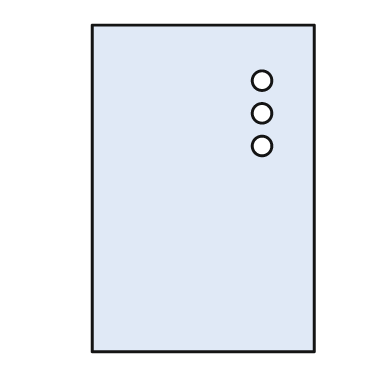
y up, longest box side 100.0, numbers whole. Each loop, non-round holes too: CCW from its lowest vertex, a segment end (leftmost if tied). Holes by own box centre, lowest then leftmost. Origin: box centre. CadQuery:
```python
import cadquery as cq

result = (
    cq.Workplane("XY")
    .moveTo(-34.0, -50.0)
    .lineTo(34.0, -50.0)
    .lineTo(34.0, 50.0)
    .lineTo(-34.0, 50.0)
    .close()
    .moveTo(18.0, 13.0)
    .circle(3.0)
    .moveTo(18.0, 23.0)
    .circle(3.0)
    .moveTo(18.0, 33.0)
    .circle(3.0)
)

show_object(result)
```